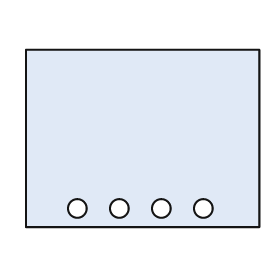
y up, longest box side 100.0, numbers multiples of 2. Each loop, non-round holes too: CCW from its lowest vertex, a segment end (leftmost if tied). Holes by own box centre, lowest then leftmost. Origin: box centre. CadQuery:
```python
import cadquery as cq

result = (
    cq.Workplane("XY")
    .moveTo(-50.0, -38.0)
    .lineTo(50.0, -38.0)
    .lineTo(50.0, 38.0)
    .lineTo(-50.0, 38.0)
    .close()
    .moveTo(-28.0, -30.0)
    .circle(4.0)
    .moveTo(-10.0, -30.0)
    .circle(4.0)
    .moveTo(8.0, -30.0)
    .circle(4.0)
    .moveTo(26.0, -30.0)
    .circle(4.0)
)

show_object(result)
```